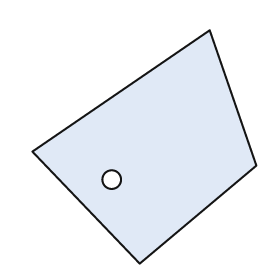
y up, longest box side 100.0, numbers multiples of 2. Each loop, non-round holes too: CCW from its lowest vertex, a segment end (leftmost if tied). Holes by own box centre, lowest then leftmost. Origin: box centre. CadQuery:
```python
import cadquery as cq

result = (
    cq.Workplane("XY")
    .moveTo(-2.0, -50.0)
    .lineTo(48.0, -8.0)
    .lineTo(28.0, 50.0)
    .lineTo(-48.0, -2.0)
    .close()
    .moveTo(-14.0, -14.0)
    .circle(4.0)
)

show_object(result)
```